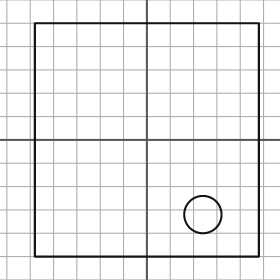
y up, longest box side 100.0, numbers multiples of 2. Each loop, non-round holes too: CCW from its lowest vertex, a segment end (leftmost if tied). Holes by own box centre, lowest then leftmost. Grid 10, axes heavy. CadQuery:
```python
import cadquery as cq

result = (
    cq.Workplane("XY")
    .moveTo(-48.0, -50.0)
    .lineTo(48.0, -50.0)
    .lineTo(48.0, 50.0)
    .lineTo(-48.0, 50.0)
    .close()
    .moveTo(24.0, -32.0)
    .circle(8.0)
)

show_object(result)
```